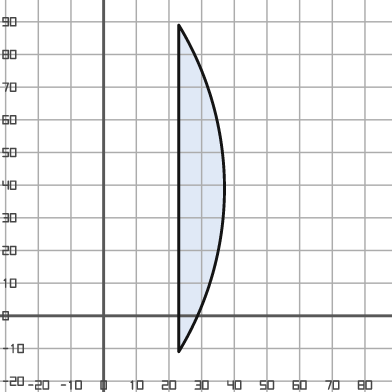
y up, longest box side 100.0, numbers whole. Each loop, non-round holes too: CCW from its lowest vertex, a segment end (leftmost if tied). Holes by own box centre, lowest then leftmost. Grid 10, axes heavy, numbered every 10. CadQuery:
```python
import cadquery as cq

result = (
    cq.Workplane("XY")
    .moveTo(23.0, -11.0)
    .threePointArc((37.0, 39.0), (23.0, 89.0))
    .close()
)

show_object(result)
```